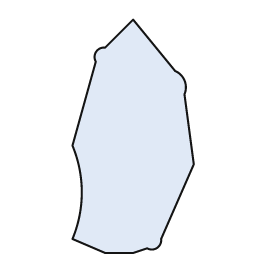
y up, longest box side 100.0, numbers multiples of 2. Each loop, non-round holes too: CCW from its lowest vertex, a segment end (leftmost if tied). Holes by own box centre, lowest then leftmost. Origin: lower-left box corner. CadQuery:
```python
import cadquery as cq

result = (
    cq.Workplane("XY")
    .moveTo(14.0, 0.0)
    .lineTo(26.0, 0.0)
    .lineTo(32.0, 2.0)
    .threePointArc((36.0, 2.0), (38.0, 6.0))
    .lineTo(52.0, 38.0)
    .lineTo(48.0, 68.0)
    .threePointArc((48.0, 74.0), (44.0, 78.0))
    .lineTo(26.0, 100.0)
    .lineTo(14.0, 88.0)
    .threePointArc((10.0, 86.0), (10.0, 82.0))
    .lineTo(0.0, 46.0)
    .threePointArc((4.0, 26.0), (0.0, 6.0))
    .close()
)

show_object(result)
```